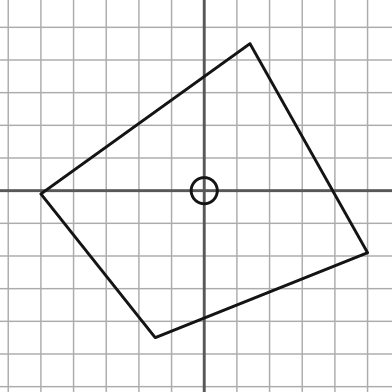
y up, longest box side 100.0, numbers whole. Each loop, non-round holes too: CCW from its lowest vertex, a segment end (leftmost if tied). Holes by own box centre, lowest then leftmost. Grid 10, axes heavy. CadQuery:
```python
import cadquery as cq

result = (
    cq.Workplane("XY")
    .moveTo(-15.0, -45.0)
    .lineTo(50.0, -19.0)
    .lineTo(14.0, 45.0)
    .lineTo(-50.0, -1.0)
    .close()
    .moveTo(0.0, 0.0)
    .circle(4.0)
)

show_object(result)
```